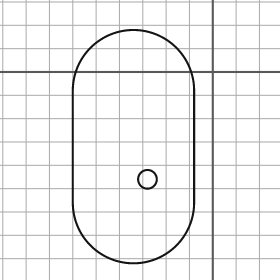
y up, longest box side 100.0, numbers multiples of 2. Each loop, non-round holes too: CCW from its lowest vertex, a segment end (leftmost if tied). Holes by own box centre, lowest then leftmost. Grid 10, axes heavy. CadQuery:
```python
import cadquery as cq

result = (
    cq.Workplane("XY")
    .moveTo(-60.0, -56.0)
    .threePointArc((-34.0, -82.0), (-8.0, -56.0))
    .lineTo(-8.0, -8.0)
    .threePointArc((-34.0, 18.0), (-60.0, -8.0))
    .close()
    .moveTo(-28.0, -46.0)
    .circle(4.0)
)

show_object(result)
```